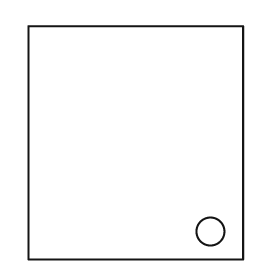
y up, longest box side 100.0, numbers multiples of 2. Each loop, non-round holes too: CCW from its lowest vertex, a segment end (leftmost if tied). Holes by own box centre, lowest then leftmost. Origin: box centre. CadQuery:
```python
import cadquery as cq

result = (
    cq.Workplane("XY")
    .moveTo(-46.0, -50.0)
    .lineTo(46.0, -50.0)
    .lineTo(46.0, 50.0)
    .lineTo(-46.0, 50.0)
    .close()
    .moveTo(32.0, -38.0)
    .circle(6.0)
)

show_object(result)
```